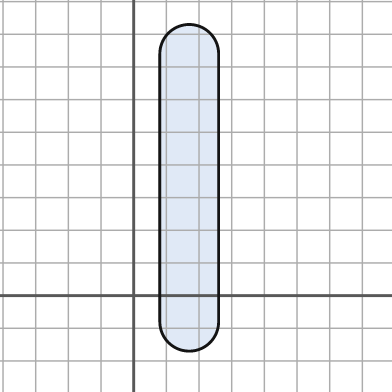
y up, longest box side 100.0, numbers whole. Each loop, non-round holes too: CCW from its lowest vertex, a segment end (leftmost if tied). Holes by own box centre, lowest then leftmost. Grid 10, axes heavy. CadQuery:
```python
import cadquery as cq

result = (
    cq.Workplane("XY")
    .moveTo(8.0, -8.0)
    .threePointArc((17.0, -17.0), (26.0, -8.0))
    .lineTo(26.0, 74.0)
    .threePointArc((17.0, 83.0), (8.0, 74.0))
    .close()
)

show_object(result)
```